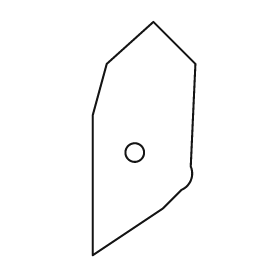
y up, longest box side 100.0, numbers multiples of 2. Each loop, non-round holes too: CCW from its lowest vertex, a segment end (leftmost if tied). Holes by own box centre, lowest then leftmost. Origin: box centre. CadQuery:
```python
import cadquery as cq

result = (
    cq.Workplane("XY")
    .moveTo(-22.0, -50.0)
    .lineTo(8.0, -30.0)
    .lineTo(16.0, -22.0)
    .threePointArc((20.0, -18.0), (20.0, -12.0))
    .lineTo(22.0, 32.0)
    .lineTo(4.0, 50.0)
    .lineTo(-16.0, 32.0)
    .lineTo(-22.0, 10.0)
    .close()
    .moveTo(-4.0, -6.0)
    .circle(4.0)
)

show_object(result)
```